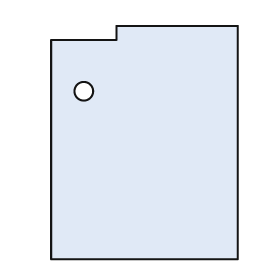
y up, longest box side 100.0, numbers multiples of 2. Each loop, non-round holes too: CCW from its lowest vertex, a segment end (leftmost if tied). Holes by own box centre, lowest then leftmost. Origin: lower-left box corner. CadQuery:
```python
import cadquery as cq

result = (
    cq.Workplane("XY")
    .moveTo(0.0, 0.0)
    .lineTo(80.0, 0.0)
    .lineTo(80.0, 100.0)
    .lineTo(28.0, 100.0)
    .lineTo(28.0, 94.0)
    .lineTo(0.0, 94.0)
    .close()
    .moveTo(14.0, 72.0)
    .circle(4.0)
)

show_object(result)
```